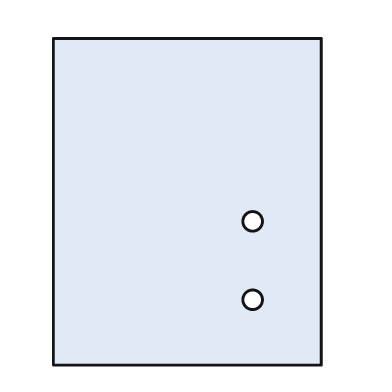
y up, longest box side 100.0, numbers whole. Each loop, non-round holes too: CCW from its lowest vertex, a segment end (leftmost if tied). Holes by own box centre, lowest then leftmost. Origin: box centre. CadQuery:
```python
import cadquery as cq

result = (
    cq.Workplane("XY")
    .moveTo(-41.0, -50.0)
    .lineTo(41.0, -50.0)
    .lineTo(41.0, 50.0)
    .lineTo(-41.0, 50.0)
    .close()
    .moveTo(20.0, -30.0)
    .circle(3.0)
    .moveTo(20.0, -6.0)
    .circle(3.0)
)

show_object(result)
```